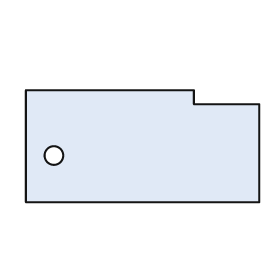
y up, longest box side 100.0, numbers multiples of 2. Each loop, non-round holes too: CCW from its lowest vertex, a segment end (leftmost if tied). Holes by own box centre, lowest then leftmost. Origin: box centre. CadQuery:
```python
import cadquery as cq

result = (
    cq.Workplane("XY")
    .moveTo(-50.0, -24.0)
    .lineTo(50.0, -24.0)
    .lineTo(50.0, 18.0)
    .lineTo(22.0, 18.0)
    .lineTo(22.0, 24.0)
    .lineTo(-50.0, 24.0)
    .close()
    .moveTo(-38.0, -4.0)
    .circle(4.0)
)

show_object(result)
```